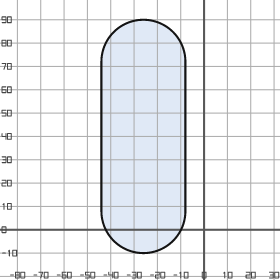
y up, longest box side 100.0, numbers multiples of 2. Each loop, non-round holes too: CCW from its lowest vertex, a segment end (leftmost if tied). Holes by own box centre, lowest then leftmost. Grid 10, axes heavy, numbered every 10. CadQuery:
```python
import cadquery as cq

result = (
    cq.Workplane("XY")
    .moveTo(-44.0, 8.0)
    .threePointArc((-26.0, -10.0), (-8.0, 8.0))
    .lineTo(-8.0, 72.0)
    .threePointArc((-26.0, 90.0), (-44.0, 72.0))
    .close()
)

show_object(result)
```